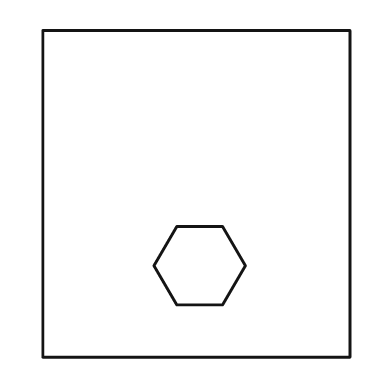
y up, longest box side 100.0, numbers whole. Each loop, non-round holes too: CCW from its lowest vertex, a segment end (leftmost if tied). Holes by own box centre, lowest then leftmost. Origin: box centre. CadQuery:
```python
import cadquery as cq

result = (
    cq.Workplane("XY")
    .moveTo(-47.0, -50.0)
    .lineTo(47.0, -50.0)
    .lineTo(47.0, 50.0)
    .lineTo(-47.0, 50.0)
    .close()
    .moveTo(-6.0, -34.0)
    .lineTo(8.0, -34.0)
    .lineTo(15.0, -22.0)
    .lineTo(8.0, -10.0)
    .lineTo(-6.0, -10.0)
    .lineTo(-13.0, -22.0)
    .close()
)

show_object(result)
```